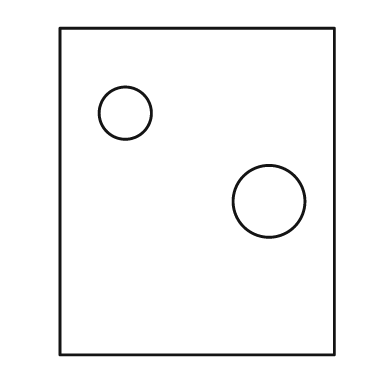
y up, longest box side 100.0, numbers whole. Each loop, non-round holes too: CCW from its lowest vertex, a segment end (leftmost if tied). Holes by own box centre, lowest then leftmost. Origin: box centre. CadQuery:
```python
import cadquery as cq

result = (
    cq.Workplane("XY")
    .moveTo(-42.0, -50.0)
    .lineTo(42.0, -50.0)
    .lineTo(42.0, 50.0)
    .lineTo(-42.0, 50.0)
    .close()
    .moveTo(22.0, -3.0)
    .circle(11.0)
    .moveTo(-22.0, 24.0)
    .circle(8.0)
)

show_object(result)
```